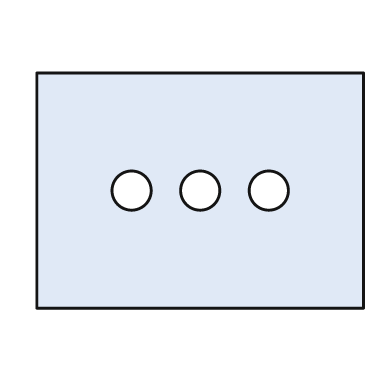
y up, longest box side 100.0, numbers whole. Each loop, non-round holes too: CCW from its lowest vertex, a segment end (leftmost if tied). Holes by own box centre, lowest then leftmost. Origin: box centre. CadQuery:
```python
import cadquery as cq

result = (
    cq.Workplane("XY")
    .moveTo(-50.0, -36.0)
    .lineTo(50.0, -36.0)
    .lineTo(50.0, 36.0)
    .lineTo(-50.0, 36.0)
    .close()
    .moveTo(-21.0, 0.0)
    .circle(6.0)
    .moveTo(0.0, 0.0)
    .circle(6.0)
    .moveTo(21.0, 0.0)
    .circle(6.0)
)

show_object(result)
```